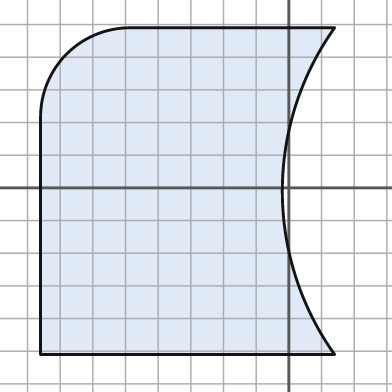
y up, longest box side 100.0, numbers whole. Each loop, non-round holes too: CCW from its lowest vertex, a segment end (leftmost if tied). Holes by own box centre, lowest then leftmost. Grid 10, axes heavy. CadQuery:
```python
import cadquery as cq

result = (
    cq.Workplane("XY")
    .moveTo(-76.0, -51.0)
    .lineTo(14.0, -51.0)
    .threePointArc((-2.0, -1.0), (14.0, 49.0))
    .lineTo(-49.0, 49.0)
    .threePointArc((-68.0, 41.0), (-76.0, 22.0))
    .close()
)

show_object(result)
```